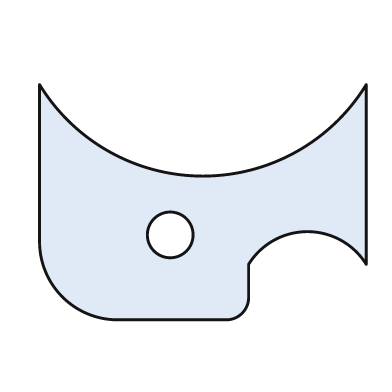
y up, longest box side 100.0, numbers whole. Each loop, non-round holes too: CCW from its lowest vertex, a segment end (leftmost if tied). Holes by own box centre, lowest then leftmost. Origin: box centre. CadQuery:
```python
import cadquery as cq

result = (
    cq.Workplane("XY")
    .moveTo(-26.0, -36.0)
    .lineTo(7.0, -36.0)
    .threePointArc((12.0, -34.0), (14.0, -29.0))
    .lineTo(14.0, -19.0)
    .threePointArc((32.0, -9.0), (50.0, -19.0))
    .lineTo(50.0, 36.0)
    .threePointArc((0.0, 8.0), (-50.0, 36.0))
    .lineTo(-50.0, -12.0)
    .threePointArc((-43.0, -29.0), (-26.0, -36.0))
    .close()
    .moveTo(-10.0, -10.0)
    .circle(7.0)
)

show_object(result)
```